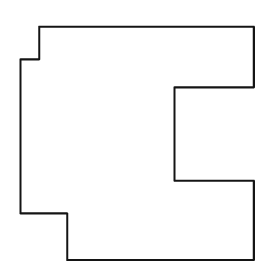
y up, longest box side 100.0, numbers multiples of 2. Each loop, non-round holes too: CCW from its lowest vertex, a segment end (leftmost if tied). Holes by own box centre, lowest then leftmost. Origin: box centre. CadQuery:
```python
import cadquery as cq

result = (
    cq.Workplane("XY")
    .moveTo(-30.0, -50.0)
    .lineTo(50.0, -50.0)
    .lineTo(50.0, -16.0)
    .lineTo(16.0, -16.0)
    .lineTo(16.0, 24.0)
    .lineTo(50.0, 24.0)
    .lineTo(50.0, 50.0)
    .lineTo(-42.0, 50.0)
    .lineTo(-42.0, 36.0)
    .lineTo(-50.0, 36.0)
    .lineTo(-50.0, -30.0)
    .lineTo(-30.0, -30.0)
    .close()
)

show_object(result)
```